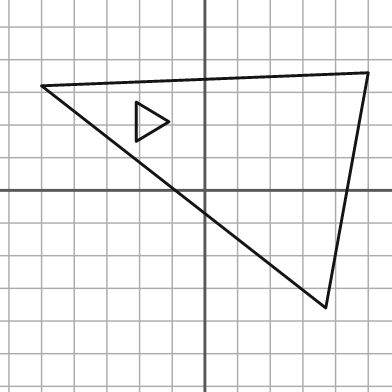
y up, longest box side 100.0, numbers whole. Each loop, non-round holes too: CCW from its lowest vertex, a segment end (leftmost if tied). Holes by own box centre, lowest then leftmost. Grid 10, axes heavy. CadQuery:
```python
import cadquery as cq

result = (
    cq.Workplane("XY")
    .moveTo(37.0, -36.0)
    .lineTo(50.0, 36.0)
    .lineTo(-50.0, 32.0)
    .close()
    .moveTo(-21.0, 15.0)
    .lineTo(-11.0, 21.0)
    .lineTo(-21.0, 27.0)
    .close()
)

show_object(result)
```